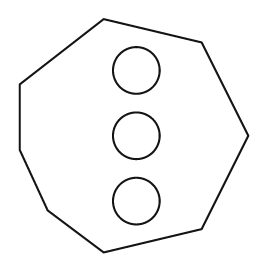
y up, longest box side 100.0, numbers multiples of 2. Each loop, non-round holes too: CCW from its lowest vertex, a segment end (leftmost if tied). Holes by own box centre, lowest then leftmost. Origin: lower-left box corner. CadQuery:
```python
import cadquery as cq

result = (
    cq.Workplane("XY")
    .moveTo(36.0, 0.0)
    .lineTo(78.0, 10.0)
    .lineTo(98.0, 50.0)
    .lineTo(78.0, 90.0)
    .lineTo(36.0, 100.0)
    .lineTo(0.0, 72.0)
    .lineTo(0.0, 44.0)
    .lineTo(12.0, 18.0)
    .close()
    .moveTo(50.0, 22.0)
    .circle(10.0)
    .moveTo(50.0, 50.0)
    .circle(10.0)
    .moveTo(50.0, 78.0)
    .circle(10.0)
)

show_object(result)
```